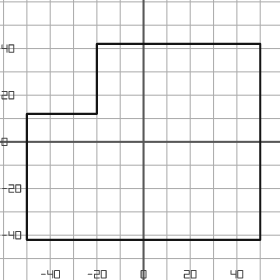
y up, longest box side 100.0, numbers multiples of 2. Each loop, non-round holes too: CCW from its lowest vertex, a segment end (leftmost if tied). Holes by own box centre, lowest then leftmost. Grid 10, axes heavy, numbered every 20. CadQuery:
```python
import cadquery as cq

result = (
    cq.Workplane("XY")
    .moveTo(-50.0, -42.0)
    .lineTo(50.0, -42.0)
    .lineTo(50.0, 42.0)
    .lineTo(-20.0, 42.0)
    .lineTo(-20.0, 12.0)
    .lineTo(-50.0, 12.0)
    .close()
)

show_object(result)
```